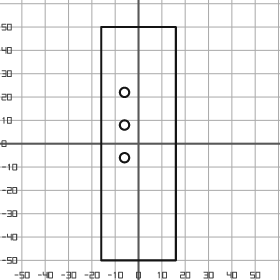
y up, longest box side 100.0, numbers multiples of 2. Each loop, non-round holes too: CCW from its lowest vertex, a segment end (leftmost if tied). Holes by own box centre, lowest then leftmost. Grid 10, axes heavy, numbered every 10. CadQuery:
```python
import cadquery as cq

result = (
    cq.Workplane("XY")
    .moveTo(-16.0, -50.0)
    .lineTo(16.0, -50.0)
    .lineTo(16.0, 50.0)
    .lineTo(-16.0, 50.0)
    .close()
    .moveTo(-6.0, -6.0)
    .circle(2.0)
    .moveTo(-6.0, 8.0)
    .circle(2.0)
    .moveTo(-6.0, 22.0)
    .circle(2.0)
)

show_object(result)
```